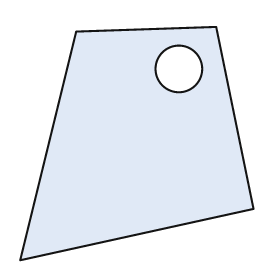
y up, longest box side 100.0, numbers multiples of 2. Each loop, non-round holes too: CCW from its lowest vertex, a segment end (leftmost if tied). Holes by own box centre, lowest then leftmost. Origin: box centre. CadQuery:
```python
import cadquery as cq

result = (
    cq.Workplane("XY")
    .moveTo(-50.0, -50.0)
    .lineTo(50.0, -28.0)
    .lineTo(34.0, 50.0)
    .lineTo(-26.0, 48.0)
    .close()
    .moveTo(18.0, 32.0)
    .circle(10.0)
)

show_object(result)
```